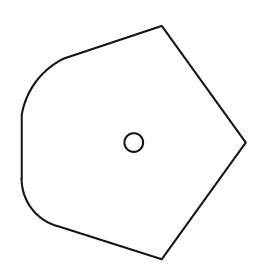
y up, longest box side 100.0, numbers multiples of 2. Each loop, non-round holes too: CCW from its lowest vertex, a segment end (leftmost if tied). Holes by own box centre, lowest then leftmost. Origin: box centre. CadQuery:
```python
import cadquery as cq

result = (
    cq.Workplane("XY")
    .moveTo(12.0, -50.0)
    .lineTo(48.0, 0.0)
    .lineTo(12.0, 50.0)
    .lineTo(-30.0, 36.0)
    .threePointArc((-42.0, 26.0), (-48.0, 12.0))
    .lineTo(-48.0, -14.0)
    .threePointArc((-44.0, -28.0), (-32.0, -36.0))
    .close()
    .moveTo(0.0, 0.0)
    .circle(4.0)
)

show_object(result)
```